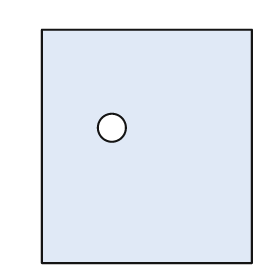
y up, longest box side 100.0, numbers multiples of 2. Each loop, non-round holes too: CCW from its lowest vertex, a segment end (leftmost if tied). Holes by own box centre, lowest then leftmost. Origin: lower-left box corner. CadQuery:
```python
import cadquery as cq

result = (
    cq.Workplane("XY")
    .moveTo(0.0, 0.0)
    .lineTo(90.0, 0.0)
    .lineTo(90.0, 100.0)
    .lineTo(0.0, 100.0)
    .close()
    .moveTo(30.0, 58.0)
    .circle(6.0)
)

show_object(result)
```